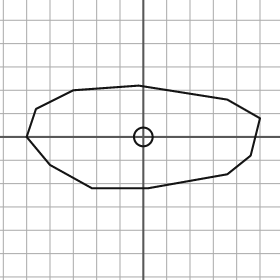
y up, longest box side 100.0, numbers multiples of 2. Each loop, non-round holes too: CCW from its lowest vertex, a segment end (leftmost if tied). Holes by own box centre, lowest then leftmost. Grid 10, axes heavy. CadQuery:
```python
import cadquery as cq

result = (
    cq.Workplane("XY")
    .moveTo(-22.0, -22.0)
    .lineTo(2.0, -22.0)
    .lineTo(36.0, -16.0)
    .lineTo(46.0, -8.0)
    .lineTo(50.0, 8.0)
    .lineTo(36.0, 16.0)
    .lineTo(-2.0, 22.0)
    .lineTo(-30.0, 20.0)
    .lineTo(-46.0, 12.0)
    .lineTo(-50.0, 0.0)
    .lineTo(-40.0, -12.0)
    .close()
    .moveTo(0.0, 0.0)
    .circle(4.0)
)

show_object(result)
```